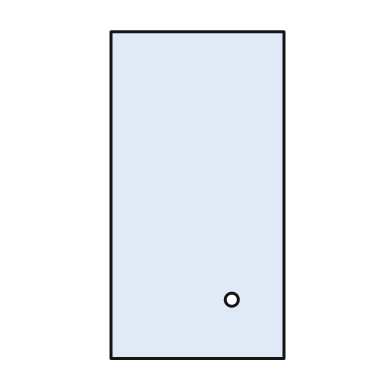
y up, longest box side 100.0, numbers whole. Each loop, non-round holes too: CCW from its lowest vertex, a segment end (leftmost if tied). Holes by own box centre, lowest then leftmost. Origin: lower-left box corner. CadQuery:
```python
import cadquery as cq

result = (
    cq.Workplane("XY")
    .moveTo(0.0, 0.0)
    .lineTo(53.0, 0.0)
    .lineTo(53.0, 100.0)
    .lineTo(0.0, 100.0)
    .close()
    .moveTo(37.0, 18.0)
    .circle(2.0)
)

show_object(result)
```